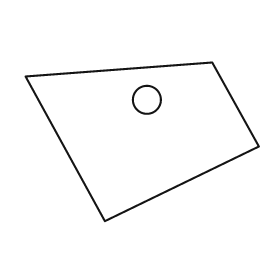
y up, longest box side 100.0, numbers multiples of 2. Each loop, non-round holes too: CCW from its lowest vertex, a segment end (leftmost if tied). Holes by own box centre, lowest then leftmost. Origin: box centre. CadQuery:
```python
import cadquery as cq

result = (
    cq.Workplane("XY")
    .moveTo(-16.0, -34.0)
    .lineTo(50.0, -2.0)
    .lineTo(30.0, 34.0)
    .lineTo(-50.0, 28.0)
    .close()
    .moveTo(2.0, 18.0)
    .circle(6.0)
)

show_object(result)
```